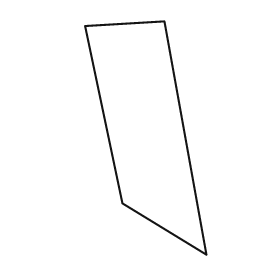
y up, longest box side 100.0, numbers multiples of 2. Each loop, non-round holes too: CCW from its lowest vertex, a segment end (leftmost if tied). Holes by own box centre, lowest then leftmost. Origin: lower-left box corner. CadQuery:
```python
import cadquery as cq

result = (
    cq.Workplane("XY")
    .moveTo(52.0, 0.0)
    .lineTo(34.0, 100.0)
    .lineTo(0.0, 98.0)
    .lineTo(16.0, 22.0)
    .close()
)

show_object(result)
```